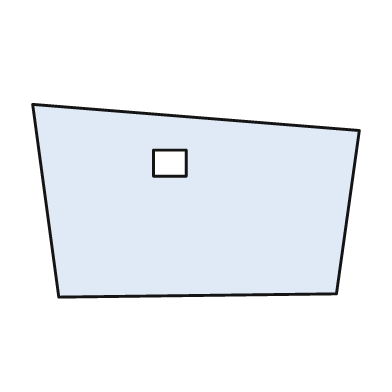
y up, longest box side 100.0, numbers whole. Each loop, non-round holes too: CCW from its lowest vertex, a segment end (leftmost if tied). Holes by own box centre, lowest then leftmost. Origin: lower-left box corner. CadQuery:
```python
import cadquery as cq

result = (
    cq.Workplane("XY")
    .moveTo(8.0, 0.0)
    .lineTo(93.0, 1.0)
    .lineTo(100.0, 51.0)
    .lineTo(0.0, 59.0)
    .close()
    .moveTo(37.0, 37.0)
    .lineTo(47.0, 37.0)
    .lineTo(47.0, 45.0)
    .lineTo(37.0, 45.0)
    .close()
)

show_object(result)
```